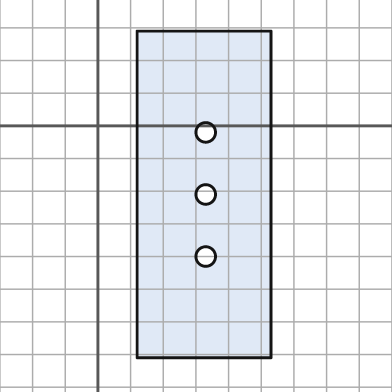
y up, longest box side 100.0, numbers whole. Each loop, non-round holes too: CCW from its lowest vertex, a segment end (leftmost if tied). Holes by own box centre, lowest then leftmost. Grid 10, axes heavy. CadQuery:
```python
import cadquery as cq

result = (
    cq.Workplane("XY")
    .moveTo(12.0, -71.0)
    .lineTo(53.0, -71.0)
    .lineTo(53.0, 29.0)
    .lineTo(12.0, 29.0)
    .close()
    .moveTo(33.0, -40.0)
    .circle(3.0)
    .moveTo(33.0, -21.0)
    .circle(3.0)
    .moveTo(33.0, -2.0)
    .circle(3.0)
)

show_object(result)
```